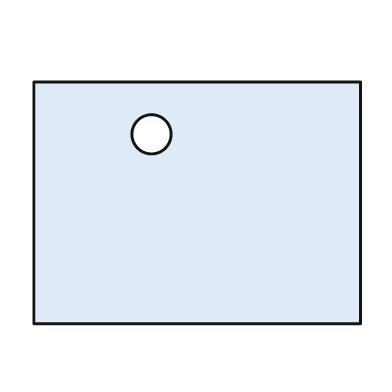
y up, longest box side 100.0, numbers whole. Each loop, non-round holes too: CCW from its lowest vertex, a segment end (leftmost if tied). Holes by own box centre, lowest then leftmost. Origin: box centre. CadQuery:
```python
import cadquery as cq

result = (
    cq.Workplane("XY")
    .moveTo(-50.0, -37.0)
    .lineTo(50.0, -37.0)
    .lineTo(50.0, 37.0)
    .lineTo(-50.0, 37.0)
    .close()
    .moveTo(-14.0, 21.0)
    .circle(6.0)
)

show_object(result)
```